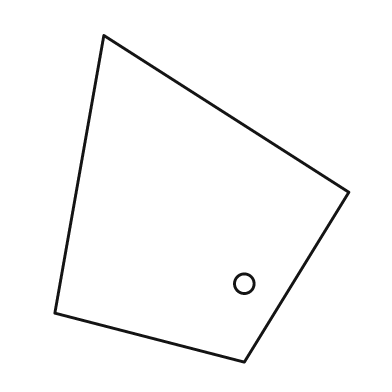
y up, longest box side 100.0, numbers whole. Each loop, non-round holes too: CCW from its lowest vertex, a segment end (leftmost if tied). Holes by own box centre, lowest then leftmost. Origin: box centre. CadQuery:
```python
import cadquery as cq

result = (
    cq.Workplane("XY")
    .moveTo(13.0, -50.0)
    .lineTo(45.0, 2.0)
    .lineTo(-30.0, 50.0)
    .lineTo(-45.0, -35.0)
    .close()
    .moveTo(13.0, -26.0)
    .circle(3.0)
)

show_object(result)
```